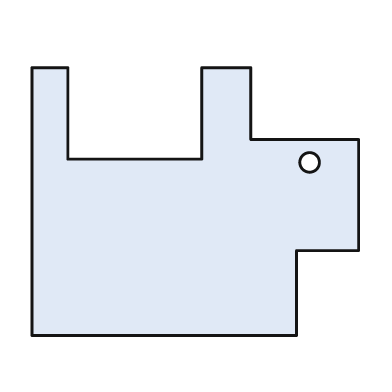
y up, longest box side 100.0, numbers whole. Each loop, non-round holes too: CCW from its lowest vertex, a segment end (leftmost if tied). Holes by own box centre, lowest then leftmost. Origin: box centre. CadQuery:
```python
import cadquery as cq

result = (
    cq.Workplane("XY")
    .moveTo(-50.0, -41.0)
    .lineTo(31.0, -41.0)
    .lineTo(31.0, -15.0)
    .lineTo(50.0, -15.0)
    .lineTo(50.0, 19.0)
    .lineTo(17.0, 19.0)
    .lineTo(17.0, 41.0)
    .lineTo(2.0, 41.0)
    .lineTo(2.0, 13.0)
    .lineTo(-39.0, 13.0)
    .lineTo(-39.0, 41.0)
    .lineTo(-50.0, 41.0)
    .close()
    .moveTo(35.0, 12.0)
    .circle(3.0)
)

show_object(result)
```